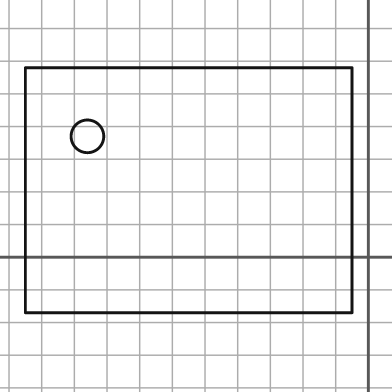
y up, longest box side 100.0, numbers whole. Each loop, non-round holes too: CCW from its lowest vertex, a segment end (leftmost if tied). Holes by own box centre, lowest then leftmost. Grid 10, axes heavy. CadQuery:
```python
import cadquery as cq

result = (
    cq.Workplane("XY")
    .moveTo(-105.0, -17.0)
    .lineTo(-5.0, -17.0)
    .lineTo(-5.0, 58.0)
    .lineTo(-105.0, 58.0)
    .close()
    .moveTo(-86.0, 37.0)
    .circle(5.0)
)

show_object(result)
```